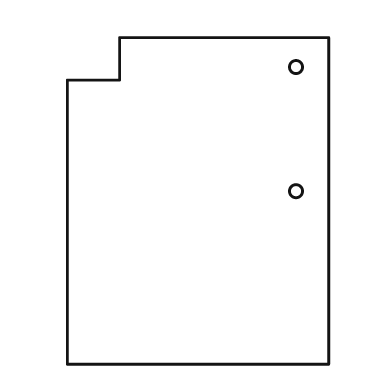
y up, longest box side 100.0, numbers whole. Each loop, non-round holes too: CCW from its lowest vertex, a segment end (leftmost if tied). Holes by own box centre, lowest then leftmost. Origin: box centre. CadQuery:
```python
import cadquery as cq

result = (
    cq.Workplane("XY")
    .moveTo(-40.0, -50.0)
    .lineTo(40.0, -50.0)
    .lineTo(40.0, 50.0)
    .lineTo(-24.0, 50.0)
    .lineTo(-24.0, 37.0)
    .lineTo(-40.0, 37.0)
    .close()
    .moveTo(30.0, 3.0)
    .circle(2.0)
    .moveTo(30.0, 41.0)
    .circle(2.0)
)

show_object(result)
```